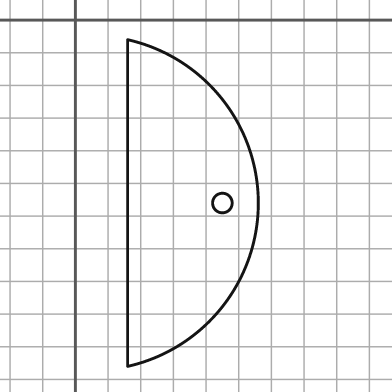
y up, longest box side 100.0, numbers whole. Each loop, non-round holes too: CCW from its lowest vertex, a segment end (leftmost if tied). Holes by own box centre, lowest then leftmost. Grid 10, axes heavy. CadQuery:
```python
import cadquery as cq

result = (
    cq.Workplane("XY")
    .moveTo(16.0, -106.0)
    .threePointArc((56.0, -56.0), (16.0, -6.0))
    .close()
    .moveTo(45.0, -56.0)
    .circle(3.0)
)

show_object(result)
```